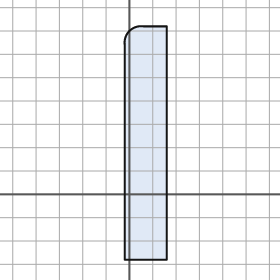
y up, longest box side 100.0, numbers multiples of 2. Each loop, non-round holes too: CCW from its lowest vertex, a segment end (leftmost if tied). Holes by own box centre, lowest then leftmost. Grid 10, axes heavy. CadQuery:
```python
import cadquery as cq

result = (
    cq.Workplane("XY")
    .moveTo(-2.0, -28.0)
    .lineTo(16.0, -28.0)
    .lineTo(16.0, 72.0)
    .lineTo(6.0, 72.0)
    .threePointArc((0.0, 70.0), (-2.0, 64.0))
    .close()
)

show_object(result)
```